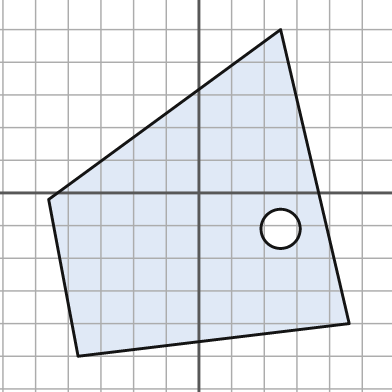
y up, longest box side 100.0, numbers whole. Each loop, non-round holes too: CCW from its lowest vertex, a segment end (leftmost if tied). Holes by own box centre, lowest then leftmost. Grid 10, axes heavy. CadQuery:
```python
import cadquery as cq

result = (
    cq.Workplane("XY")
    .moveTo(-37.0, -50.0)
    .lineTo(46.0, -40.0)
    .lineTo(25.0, 50.0)
    .lineTo(-46.0, -2.0)
    .close()
    .moveTo(25.0, -11.0)
    .circle(6.0)
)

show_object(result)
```